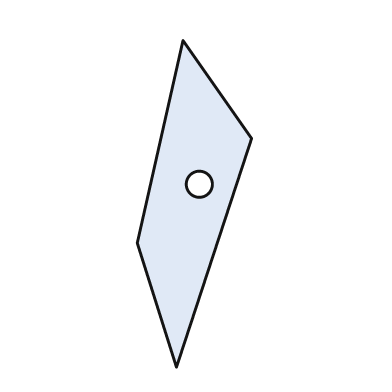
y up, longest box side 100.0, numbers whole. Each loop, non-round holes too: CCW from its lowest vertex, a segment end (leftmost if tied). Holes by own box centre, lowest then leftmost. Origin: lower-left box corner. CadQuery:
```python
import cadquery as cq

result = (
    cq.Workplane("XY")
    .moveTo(12.0, 0.0)
    .lineTo(35.0, 70.0)
    .lineTo(14.0, 100.0)
    .lineTo(0.0, 38.0)
    .close()
    .moveTo(19.0, 56.0)
    .circle(4.0)
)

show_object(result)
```